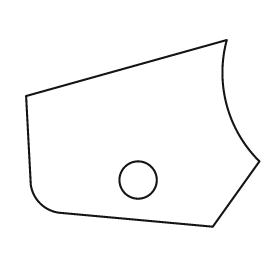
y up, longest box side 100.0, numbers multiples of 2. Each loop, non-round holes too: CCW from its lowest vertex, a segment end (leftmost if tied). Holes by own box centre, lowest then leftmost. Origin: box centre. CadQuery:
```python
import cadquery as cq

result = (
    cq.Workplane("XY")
    .moveTo(30.0, -40.0)
    .lineTo(50.0, -12.0)
    .threePointArc((36.0, 12.0), (36.0, 40.0))
    .lineTo(-50.0, 16.0)
    .lineTo(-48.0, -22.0)
    .threePointArc((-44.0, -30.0), (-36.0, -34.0))
    .close()
    .moveTo(-2.0, -20.0)
    .circle(8.0)
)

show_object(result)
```